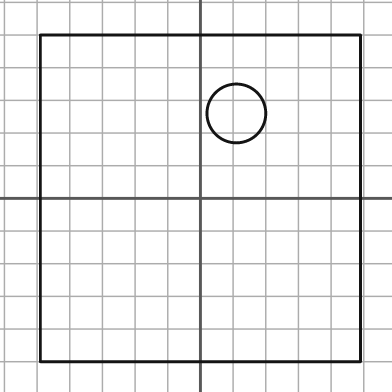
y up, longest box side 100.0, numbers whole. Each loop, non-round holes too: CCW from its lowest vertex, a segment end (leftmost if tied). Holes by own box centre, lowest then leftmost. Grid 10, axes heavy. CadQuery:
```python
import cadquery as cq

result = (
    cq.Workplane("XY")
    .moveTo(-49.0, -50.0)
    .lineTo(49.0, -50.0)
    .lineTo(49.0, 50.0)
    .lineTo(-49.0, 50.0)
    .close()
    .moveTo(11.0, 26.0)
    .circle(9.0)
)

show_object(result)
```